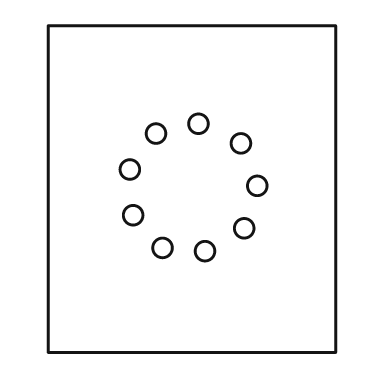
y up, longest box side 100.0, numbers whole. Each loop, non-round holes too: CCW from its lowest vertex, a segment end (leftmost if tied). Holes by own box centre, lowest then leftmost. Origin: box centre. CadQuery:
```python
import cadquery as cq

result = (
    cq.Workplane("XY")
    .moveTo(-44.0, -50.0)
    .lineTo(44.0, -50.0)
    .lineTo(44.0, 50.0)
    .lineTo(-44.0, 50.0)
    .close()
    .moveTo(4.0, -19.0)
    .circle(3.0)
    .moveTo(-9.0, -18.0)
    .circle(3.0)
    .moveTo(16.0, -12.0)
    .circle(3.0)
    .moveTo(-18.0, -8.0)
    .circle(3.0)
    .moveTo(20.0, 1.0)
    .circle(3.0)
    .moveTo(-19.0, 6.0)
    .circle(3.0)
    .moveTo(15.0, 14.0)
    .circle(3.0)
    .moveTo(-11.0, 17.0)
    .circle(3.0)
    .moveTo(2.0, 20.0)
    .circle(3.0)
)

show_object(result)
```